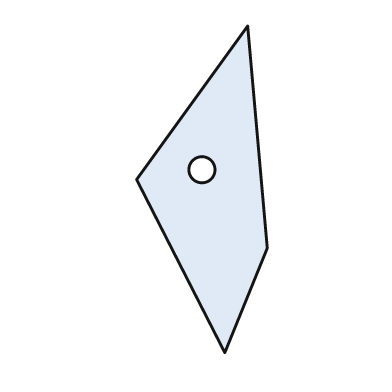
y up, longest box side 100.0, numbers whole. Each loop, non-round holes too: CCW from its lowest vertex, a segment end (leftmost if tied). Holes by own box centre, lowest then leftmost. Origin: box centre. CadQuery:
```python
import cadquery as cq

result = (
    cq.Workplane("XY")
    .moveTo(7.0, -50.0)
    .lineTo(20.0, -18.0)
    .lineTo(14.0, 50.0)
    .lineTo(-20.0, 3.0)
    .close()
    .moveTo(0.0, 6.0)
    .circle(4.0)
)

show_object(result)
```